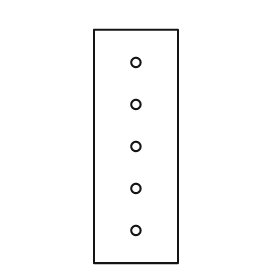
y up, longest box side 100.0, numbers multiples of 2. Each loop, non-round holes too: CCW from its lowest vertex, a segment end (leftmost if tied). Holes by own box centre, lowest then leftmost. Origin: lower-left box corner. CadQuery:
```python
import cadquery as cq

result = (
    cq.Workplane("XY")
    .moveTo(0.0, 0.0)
    .lineTo(36.0, 0.0)
    .lineTo(36.0, 100.0)
    .lineTo(0.0, 100.0)
    .close()
    .moveTo(18.0, 14.0)
    .circle(2.0)
    .moveTo(18.0, 32.0)
    .circle(2.0)
    .moveTo(18.0, 50.0)
    .circle(2.0)
    .moveTo(18.0, 68.0)
    .circle(2.0)
    .moveTo(18.0, 86.0)
    .circle(2.0)
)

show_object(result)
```